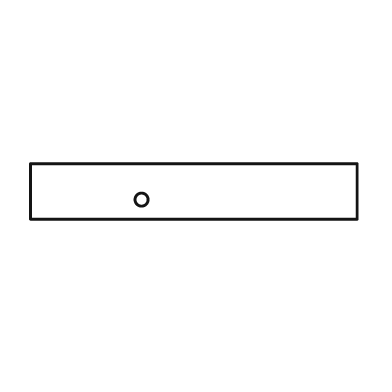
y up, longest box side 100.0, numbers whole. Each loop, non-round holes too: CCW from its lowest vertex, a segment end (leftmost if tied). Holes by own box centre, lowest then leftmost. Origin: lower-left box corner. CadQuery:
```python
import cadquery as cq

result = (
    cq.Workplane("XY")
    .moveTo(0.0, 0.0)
    .lineTo(100.0, 0.0)
    .lineTo(100.0, 17.0)
    .lineTo(0.0, 17.0)
    .close()
    .moveTo(34.0, 6.0)
    .circle(2.0)
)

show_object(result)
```